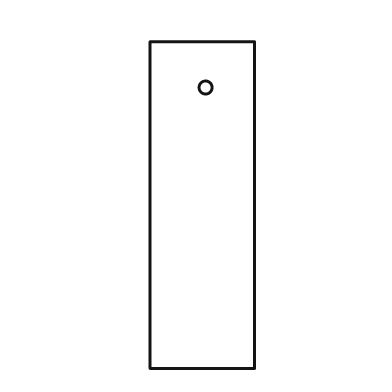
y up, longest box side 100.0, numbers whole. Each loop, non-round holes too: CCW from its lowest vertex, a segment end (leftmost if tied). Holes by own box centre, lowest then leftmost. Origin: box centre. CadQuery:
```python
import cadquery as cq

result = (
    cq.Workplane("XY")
    .moveTo(-16.0, -50.0)
    .lineTo(16.0, -50.0)
    .lineTo(16.0, 50.0)
    .lineTo(-16.0, 50.0)
    .close()
    .moveTo(1.0, 36.0)
    .circle(2.0)
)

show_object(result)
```